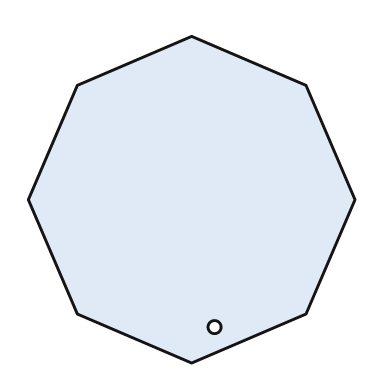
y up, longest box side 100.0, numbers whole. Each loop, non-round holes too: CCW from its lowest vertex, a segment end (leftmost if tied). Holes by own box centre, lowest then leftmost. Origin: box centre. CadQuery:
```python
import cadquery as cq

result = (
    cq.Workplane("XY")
    .moveTo(0.0, -50.0)
    .lineTo(35.0, -35.0)
    .lineTo(50.0, 0.0)
    .lineTo(35.0, 35.0)
    .lineTo(0.0, 50.0)
    .lineTo(-35.0, 35.0)
    .lineTo(-50.0, 0.0)
    .lineTo(-35.0, -35.0)
    .close()
    .moveTo(7.0, -39.0)
    .circle(2.0)
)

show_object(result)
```